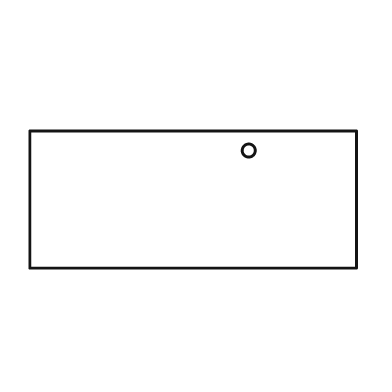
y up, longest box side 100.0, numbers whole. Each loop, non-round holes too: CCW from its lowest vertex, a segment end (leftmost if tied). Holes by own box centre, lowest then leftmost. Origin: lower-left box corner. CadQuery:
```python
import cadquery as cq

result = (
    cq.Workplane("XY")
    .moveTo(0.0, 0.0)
    .lineTo(100.0, 0.0)
    .lineTo(100.0, 42.0)
    .lineTo(0.0, 42.0)
    .close()
    .moveTo(67.0, 36.0)
    .circle(2.0)
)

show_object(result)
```